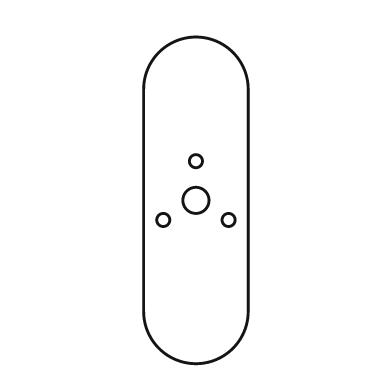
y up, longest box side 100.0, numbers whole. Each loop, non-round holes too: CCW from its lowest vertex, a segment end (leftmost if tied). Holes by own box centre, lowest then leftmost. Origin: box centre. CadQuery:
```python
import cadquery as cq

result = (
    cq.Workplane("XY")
    .moveTo(-16.0, -34.0)
    .threePointArc((0.0, -50.0), (16.0, -34.0))
    .lineTo(16.0, 34.0)
    .threePointArc((0.0, 50.0), (-16.0, 34.0))
    .close()
    .moveTo(-10.0, -6.0)
    .circle(2.0)
    .moveTo(10.0, -6.0)
    .circle(2.0)
    .moveTo(0.0, 0.0)
    .circle(4.0)
    .moveTo(0.0, 12.0)
    .circle(2.0)
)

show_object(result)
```